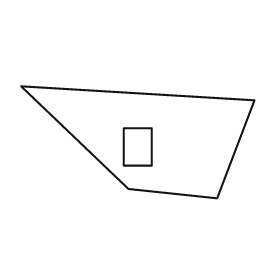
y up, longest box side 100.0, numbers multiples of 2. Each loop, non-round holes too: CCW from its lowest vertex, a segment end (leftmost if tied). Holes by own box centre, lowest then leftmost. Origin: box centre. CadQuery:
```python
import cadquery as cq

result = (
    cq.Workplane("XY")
    .moveTo(34.0, -24.0)
    .lineTo(50.0, 18.0)
    .lineTo(-50.0, 24.0)
    .lineTo(-4.0, -20.0)
    .close()
    .moveTo(-6.0, -10.0)
    .lineTo(6.0, -10.0)
    .lineTo(6.0, 6.0)
    .lineTo(-6.0, 6.0)
    .close()
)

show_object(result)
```